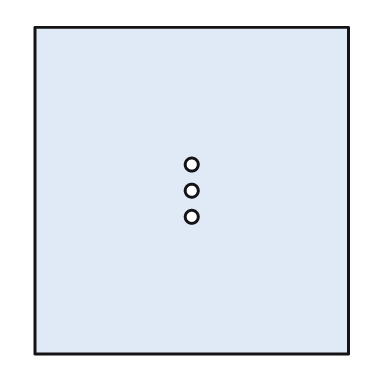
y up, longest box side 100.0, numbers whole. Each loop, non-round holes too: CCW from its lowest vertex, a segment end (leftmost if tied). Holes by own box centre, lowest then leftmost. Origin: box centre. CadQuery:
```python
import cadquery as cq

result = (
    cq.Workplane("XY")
    .moveTo(-48.0, -50.0)
    .lineTo(48.0, -50.0)
    .lineTo(48.0, 50.0)
    .lineTo(-48.0, 50.0)
    .close()
    .moveTo(0.0, -8.0)
    .circle(2.0)
    .moveTo(0.0, 0.0)
    .circle(2.0)
    .moveTo(0.0, 8.0)
    .circle(2.0)
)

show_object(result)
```